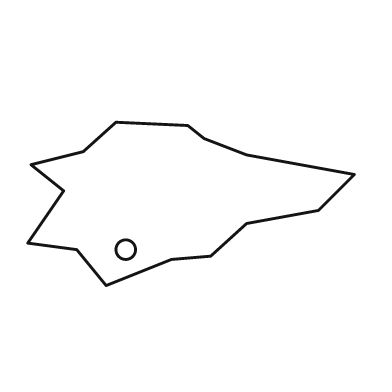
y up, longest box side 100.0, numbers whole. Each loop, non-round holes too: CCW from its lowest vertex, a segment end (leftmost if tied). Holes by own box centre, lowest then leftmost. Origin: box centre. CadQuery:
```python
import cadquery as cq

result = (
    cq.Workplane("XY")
    .moveTo(-26.0, -25.0)
    .lineTo(-6.0, -17.0)
    .lineTo(6.0, -16.0)
    .lineTo(17.0, -6.0)
    .lineTo(39.0, -2.0)
    .lineTo(50.0, 9.0)
    .lineTo(17.0, 15.0)
    .lineTo(4.0, 20.0)
    .lineTo(-1.0, 24.0)
    .lineTo(-23.0, 25.0)
    .lineTo(-33.0, 16.0)
    .lineTo(-49.0, 12.0)
    .lineTo(-39.0, 4.0)
    .lineTo(-50.0, -12.0)
    .lineTo(-35.0, -14.0)
    .close()
    .moveTo(-20.0, -14.0)
    .circle(3.0)
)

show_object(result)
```